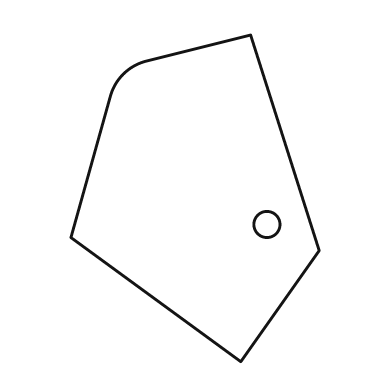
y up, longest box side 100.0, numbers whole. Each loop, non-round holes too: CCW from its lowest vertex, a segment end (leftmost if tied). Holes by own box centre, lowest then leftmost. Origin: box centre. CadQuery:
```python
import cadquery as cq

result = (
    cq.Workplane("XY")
    .moveTo(14.0, -50.0)
    .lineTo(38.0, -16.0)
    .lineTo(17.0, 50.0)
    .lineTo(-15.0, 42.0)
    .threePointArc((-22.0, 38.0), (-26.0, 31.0))
    .lineTo(-38.0, -12.0)
    .close()
    .moveTo(22.0, -8.0)
    .circle(4.0)
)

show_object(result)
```